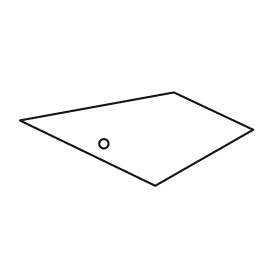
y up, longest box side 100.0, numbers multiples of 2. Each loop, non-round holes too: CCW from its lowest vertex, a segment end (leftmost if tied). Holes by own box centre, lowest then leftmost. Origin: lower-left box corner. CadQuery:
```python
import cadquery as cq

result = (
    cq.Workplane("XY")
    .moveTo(58.0, 0.0)
    .lineTo(100.0, 24.0)
    .lineTo(66.0, 40.0)
    .lineTo(0.0, 28.0)
    .close()
    .moveTo(36.0, 18.0)
    .circle(2.0)
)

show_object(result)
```